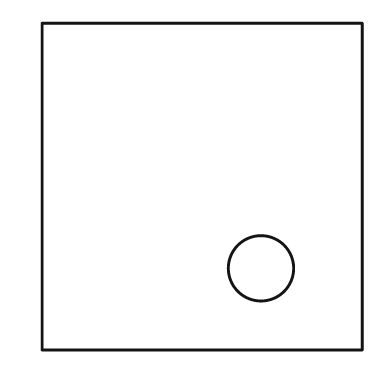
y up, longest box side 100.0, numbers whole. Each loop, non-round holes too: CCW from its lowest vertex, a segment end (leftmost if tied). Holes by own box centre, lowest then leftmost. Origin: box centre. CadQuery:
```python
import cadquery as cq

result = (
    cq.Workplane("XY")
    .moveTo(-49.0, -50.0)
    .lineTo(49.0, -50.0)
    .lineTo(49.0, 50.0)
    .lineTo(-49.0, 50.0)
    .close()
    .moveTo(18.0, -25.0)
    .circle(10.0)
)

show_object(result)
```